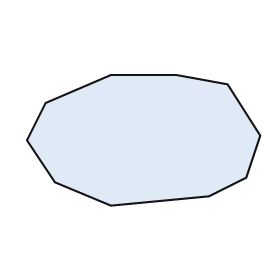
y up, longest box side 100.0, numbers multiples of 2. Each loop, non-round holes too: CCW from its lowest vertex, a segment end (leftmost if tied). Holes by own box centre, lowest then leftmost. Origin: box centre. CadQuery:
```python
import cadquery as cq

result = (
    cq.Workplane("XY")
    .moveTo(-14.0, -28.0)
    .lineTo(28.0, -24.0)
    .lineTo(44.0, -16.0)
    .lineTo(50.0, 2.0)
    .lineTo(36.0, 24.0)
    .lineTo(14.0, 28.0)
    .lineTo(-14.0, 28.0)
    .lineTo(-42.0, 16.0)
    .lineTo(-50.0, 0.0)
    .lineTo(-38.0, -18.0)
    .close()
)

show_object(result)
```